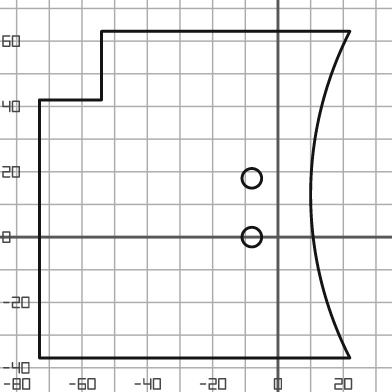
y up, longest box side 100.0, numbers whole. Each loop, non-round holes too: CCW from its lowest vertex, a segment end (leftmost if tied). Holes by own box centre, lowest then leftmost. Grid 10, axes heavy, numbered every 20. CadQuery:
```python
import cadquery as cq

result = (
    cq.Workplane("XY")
    .moveTo(-73.0, -37.0)
    .lineTo(22.0, -37.0)
    .threePointArc((10.0, 13.0), (22.0, 63.0))
    .lineTo(-54.0, 63.0)
    .lineTo(-54.0, 42.0)
    .lineTo(-73.0, 42.0)
    .close()
    .moveTo(-8.0, 0.0)
    .circle(3.0)
    .moveTo(-8.0, 18.0)
    .circle(3.0)
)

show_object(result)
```